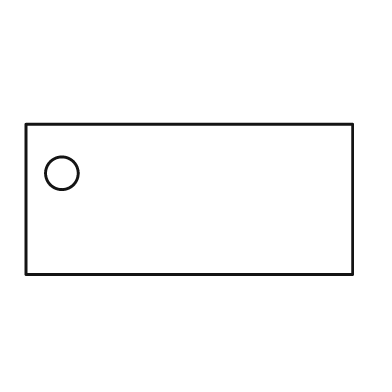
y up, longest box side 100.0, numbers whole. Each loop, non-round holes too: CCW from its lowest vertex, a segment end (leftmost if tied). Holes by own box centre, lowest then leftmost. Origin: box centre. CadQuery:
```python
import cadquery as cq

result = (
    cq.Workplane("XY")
    .moveTo(-50.0, -23.0)
    .lineTo(50.0, -23.0)
    .lineTo(50.0, 23.0)
    .lineTo(-50.0, 23.0)
    .close()
    .moveTo(-39.0, 8.0)
    .circle(5.0)
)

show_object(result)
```